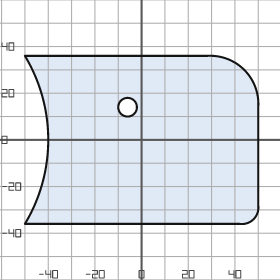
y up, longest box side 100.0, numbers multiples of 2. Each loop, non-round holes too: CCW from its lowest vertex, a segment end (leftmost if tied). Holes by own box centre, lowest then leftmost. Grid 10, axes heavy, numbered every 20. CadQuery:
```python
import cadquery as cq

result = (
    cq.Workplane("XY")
    .moveTo(-50.0, -36.0)
    .lineTo(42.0, -36.0)
    .threePointArc((48.0, -34.0), (50.0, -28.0))
    .lineTo(50.0, 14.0)
    .threePointArc((44.0, 30.0), (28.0, 36.0))
    .lineTo(-50.0, 36.0)
    .threePointArc((-40.0, 0.0), (-50.0, -36.0))
    .close()
    .moveTo(-6.0, 14.0)
    .circle(4.0)
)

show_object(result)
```